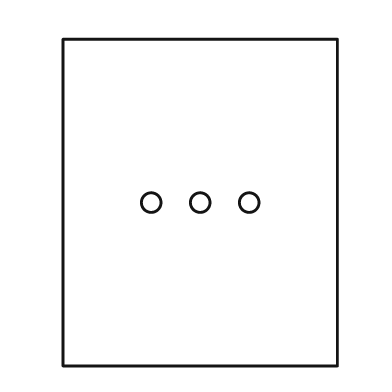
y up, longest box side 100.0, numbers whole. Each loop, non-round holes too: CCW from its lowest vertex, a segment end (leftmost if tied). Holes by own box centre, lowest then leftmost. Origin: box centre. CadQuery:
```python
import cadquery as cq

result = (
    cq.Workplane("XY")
    .moveTo(-42.0, -50.0)
    .lineTo(42.0, -50.0)
    .lineTo(42.0, 50.0)
    .lineTo(-42.0, 50.0)
    .close()
    .moveTo(-15.0, 0.0)
    .circle(3.0)
    .moveTo(0.0, 0.0)
    .circle(3.0)
    .moveTo(15.0, 0.0)
    .circle(3.0)
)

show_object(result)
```